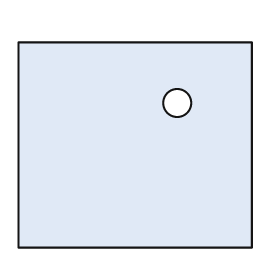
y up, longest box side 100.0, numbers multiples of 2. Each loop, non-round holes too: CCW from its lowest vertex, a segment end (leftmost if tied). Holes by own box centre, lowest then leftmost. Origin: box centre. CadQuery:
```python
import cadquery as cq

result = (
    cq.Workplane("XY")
    .moveTo(-50.0, -44.0)
    .lineTo(50.0, -44.0)
    .lineTo(50.0, 44.0)
    .lineTo(-50.0, 44.0)
    .close()
    .moveTo(18.0, 18.0)
    .circle(6.0)
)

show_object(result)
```